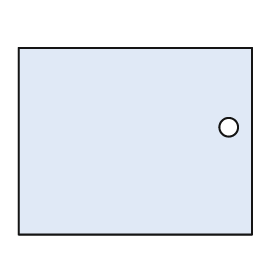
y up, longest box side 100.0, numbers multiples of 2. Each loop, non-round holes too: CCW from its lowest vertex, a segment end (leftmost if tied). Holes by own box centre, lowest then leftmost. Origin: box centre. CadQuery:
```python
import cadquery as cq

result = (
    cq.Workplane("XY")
    .moveTo(-50.0, -40.0)
    .lineTo(50.0, -40.0)
    .lineTo(50.0, 40.0)
    .lineTo(-50.0, 40.0)
    .close()
    .moveTo(40.0, 6.0)
    .circle(4.0)
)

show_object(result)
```